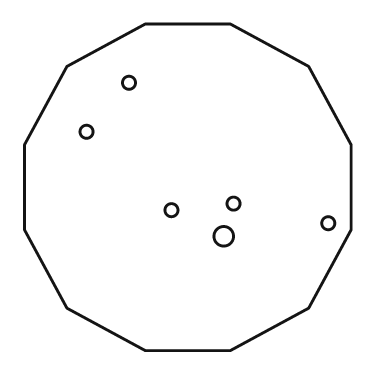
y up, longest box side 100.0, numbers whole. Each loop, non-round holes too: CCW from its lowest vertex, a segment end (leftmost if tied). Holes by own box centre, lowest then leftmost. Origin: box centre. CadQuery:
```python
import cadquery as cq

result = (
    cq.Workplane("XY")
    .moveTo(-13.0, -50.0)
    .lineTo(13.0, -50.0)
    .lineTo(37.0, -37.0)
    .lineTo(50.0, -13.0)
    .lineTo(50.0, 13.0)
    .lineTo(37.0, 37.0)
    .lineTo(13.0, 50.0)
    .lineTo(-13.0, 50.0)
    .lineTo(-37.0, 37.0)
    .lineTo(-50.0, 13.0)
    .lineTo(-50.0, -13.0)
    .lineTo(-37.0, -37.0)
    .close()
    .moveTo(11.0, -15.0)
    .circle(3.0)
    .moveTo(43.0, -11.0)
    .circle(2.0)
    .moveTo(-5.0, -7.0)
    .circle(2.0)
    .moveTo(14.0, -5.0)
    .circle(2.0)
    .moveTo(-31.0, 17.0)
    .circle(2.0)
    .moveTo(-18.0, 32.0)
    .circle(2.0)
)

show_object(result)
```